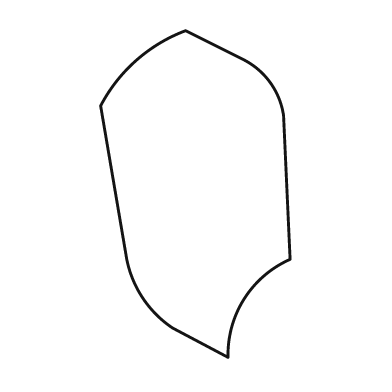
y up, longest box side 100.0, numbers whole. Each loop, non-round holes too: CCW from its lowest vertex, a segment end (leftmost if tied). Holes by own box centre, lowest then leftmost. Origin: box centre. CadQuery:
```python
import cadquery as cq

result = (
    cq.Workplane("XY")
    .moveTo(10.0, -50.0)
    .threePointArc((15.0, -32.0), (29.0, -20.0))
    .lineTo(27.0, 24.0)
    .threePointArc((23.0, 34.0), (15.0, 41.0))
    .lineTo(-3.0, 50.0)
    .threePointArc((-18.0, 41.0), (-29.0, 27.0))
    .lineTo(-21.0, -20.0)
    .threePointArc((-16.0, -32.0), (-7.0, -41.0))
    .close()
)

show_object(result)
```